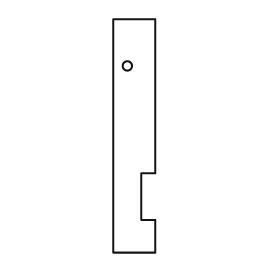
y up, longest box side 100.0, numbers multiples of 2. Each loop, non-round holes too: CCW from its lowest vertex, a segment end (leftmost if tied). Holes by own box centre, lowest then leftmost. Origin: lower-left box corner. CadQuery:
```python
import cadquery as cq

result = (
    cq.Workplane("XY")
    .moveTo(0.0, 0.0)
    .lineTo(18.0, 0.0)
    .lineTo(18.0, 14.0)
    .lineTo(12.0, 14.0)
    .lineTo(12.0, 34.0)
    .lineTo(18.0, 34.0)
    .lineTo(18.0, 100.0)
    .lineTo(0.0, 100.0)
    .close()
    .moveTo(6.0, 80.0)
    .circle(2.0)
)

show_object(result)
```